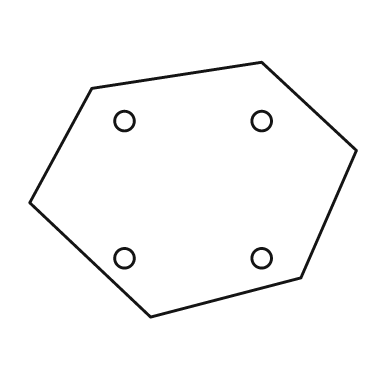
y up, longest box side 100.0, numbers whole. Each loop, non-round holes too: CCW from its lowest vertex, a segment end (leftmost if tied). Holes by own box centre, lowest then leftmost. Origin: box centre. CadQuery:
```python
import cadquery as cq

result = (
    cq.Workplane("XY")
    .moveTo(-13.0, -39.0)
    .lineTo(33.0, -27.0)
    .lineTo(50.0, 12.0)
    .lineTo(21.0, 39.0)
    .lineTo(-31.0, 31.0)
    .lineTo(-50.0, -4.0)
    .close()
    .moveTo(-21.0, -21.0)
    .circle(3.0)
    .moveTo(21.0, -21.0)
    .circle(3.0)
    .moveTo(-21.0, 21.0)
    .circle(3.0)
    .moveTo(21.0, 21.0)
    .circle(3.0)
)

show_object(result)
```